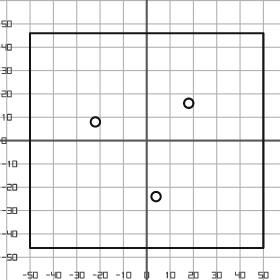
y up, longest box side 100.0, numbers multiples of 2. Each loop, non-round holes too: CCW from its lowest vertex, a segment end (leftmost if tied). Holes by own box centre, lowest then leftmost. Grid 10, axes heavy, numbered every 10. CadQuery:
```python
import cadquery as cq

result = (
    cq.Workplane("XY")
    .moveTo(-50.0, -46.0)
    .lineTo(50.0, -46.0)
    .lineTo(50.0, 46.0)
    .lineTo(-50.0, 46.0)
    .close()
    .moveTo(4.0, -24.0)
    .circle(2.0)
    .moveTo(-22.0, 8.0)
    .circle(2.0)
    .moveTo(18.0, 16.0)
    .circle(2.0)
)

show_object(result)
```